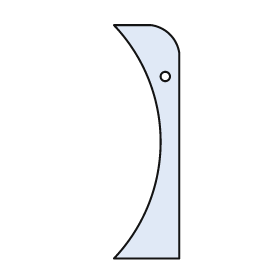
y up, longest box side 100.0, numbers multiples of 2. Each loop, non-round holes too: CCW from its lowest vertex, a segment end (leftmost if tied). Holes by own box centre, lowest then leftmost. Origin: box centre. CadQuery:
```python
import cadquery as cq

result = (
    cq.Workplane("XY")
    .moveTo(-14.0, -50.0)
    .lineTo(14.0, -50.0)
    .lineTo(14.0, 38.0)
    .threePointArc((10.0, 46.0), (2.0, 50.0))
    .lineTo(-14.0, 50.0)
    .threePointArc((6.0, 0.0), (-14.0, -50.0))
    .close()
    .moveTo(8.0, 28.0)
    .circle(2.0)
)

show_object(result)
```